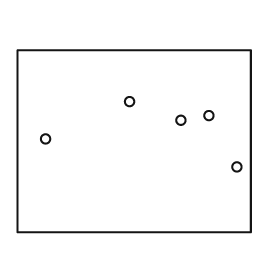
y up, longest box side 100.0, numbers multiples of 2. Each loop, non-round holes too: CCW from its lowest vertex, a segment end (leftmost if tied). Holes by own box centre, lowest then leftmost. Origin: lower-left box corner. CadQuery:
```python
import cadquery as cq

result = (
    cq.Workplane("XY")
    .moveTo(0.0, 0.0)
    .lineTo(100.0, 0.0)
    .lineTo(100.0, 78.0)
    .lineTo(0.0, 78.0)
    .close()
    .moveTo(94.0, 28.0)
    .circle(2.0)
    .moveTo(12.0, 40.0)
    .circle(2.0)
    .moveTo(70.0, 48.0)
    .circle(2.0)
    .moveTo(82.0, 50.0)
    .circle(2.0)
    .moveTo(48.0, 56.0)
    .circle(2.0)
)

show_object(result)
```